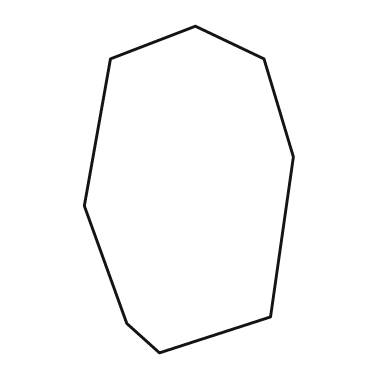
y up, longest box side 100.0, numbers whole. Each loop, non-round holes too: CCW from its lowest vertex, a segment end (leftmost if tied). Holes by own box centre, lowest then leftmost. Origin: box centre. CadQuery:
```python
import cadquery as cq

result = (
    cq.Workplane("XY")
    .moveTo(-9.0, -50.0)
    .lineTo(25.0, -39.0)
    .lineTo(32.0, 10.0)
    .lineTo(23.0, 40.0)
    .lineTo(2.0, 50.0)
    .lineTo(-24.0, 40.0)
    .lineTo(-32.0, -5.0)
    .lineTo(-19.0, -41.0)
    .close()
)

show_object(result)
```